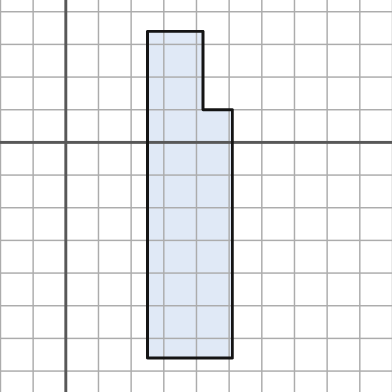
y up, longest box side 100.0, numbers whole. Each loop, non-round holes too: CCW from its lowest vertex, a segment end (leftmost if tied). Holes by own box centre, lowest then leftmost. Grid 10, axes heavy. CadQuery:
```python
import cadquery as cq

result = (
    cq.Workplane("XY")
    .moveTo(25.0, -66.0)
    .lineTo(51.0, -66.0)
    .lineTo(51.0, 10.0)
    .lineTo(42.0, 10.0)
    .lineTo(42.0, 34.0)
    .lineTo(25.0, 34.0)
    .close()
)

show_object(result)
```